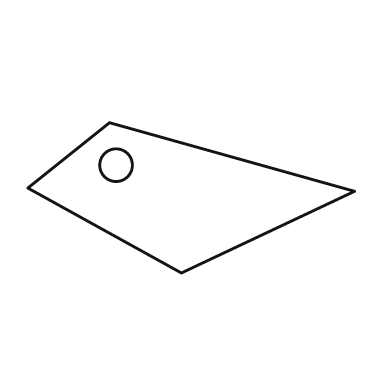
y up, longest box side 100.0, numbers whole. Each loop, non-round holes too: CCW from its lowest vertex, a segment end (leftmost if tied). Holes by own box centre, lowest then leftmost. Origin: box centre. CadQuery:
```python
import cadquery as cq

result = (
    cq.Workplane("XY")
    .moveTo(-3.0, -23.0)
    .lineTo(50.0, 2.0)
    .lineTo(-25.0, 23.0)
    .lineTo(-50.0, 3.0)
    .close()
    .moveTo(-23.0, 10.0)
    .circle(5.0)
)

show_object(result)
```